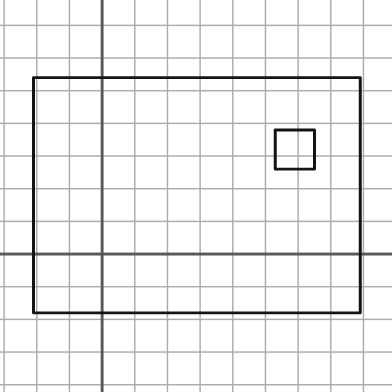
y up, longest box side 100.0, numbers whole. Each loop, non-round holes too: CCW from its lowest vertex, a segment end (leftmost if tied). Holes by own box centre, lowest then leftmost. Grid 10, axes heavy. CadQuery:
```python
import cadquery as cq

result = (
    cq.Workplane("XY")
    .moveTo(-21.0, -18.0)
    .lineTo(79.0, -18.0)
    .lineTo(79.0, 54.0)
    .lineTo(-21.0, 54.0)
    .close()
    .moveTo(53.0, 26.0)
    .lineTo(65.0, 26.0)
    .lineTo(65.0, 38.0)
    .lineTo(53.0, 38.0)
    .close()
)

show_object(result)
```